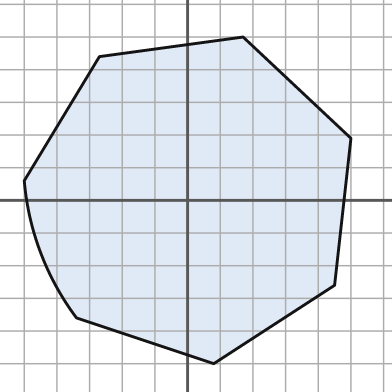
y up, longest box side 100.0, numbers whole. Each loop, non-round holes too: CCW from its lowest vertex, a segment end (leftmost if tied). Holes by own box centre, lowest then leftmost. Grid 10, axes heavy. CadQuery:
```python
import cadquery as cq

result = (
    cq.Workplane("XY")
    .moveTo(8.0, -50.0)
    .lineTo(45.0, -26.0)
    .lineTo(50.0, 19.0)
    .lineTo(17.0, 50.0)
    .lineTo(-27.0, 44.0)
    .lineTo(-50.0, 6.0)
    .threePointArc((-45.0, -16.0), (-34.0, -36.0))
    .close()
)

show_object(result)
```